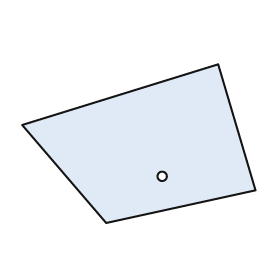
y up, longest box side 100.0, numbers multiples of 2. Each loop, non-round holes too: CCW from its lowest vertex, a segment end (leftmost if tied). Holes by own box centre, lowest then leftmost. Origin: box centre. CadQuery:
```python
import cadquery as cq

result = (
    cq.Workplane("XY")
    .moveTo(-14.0, -34.0)
    .lineTo(50.0, -20.0)
    .lineTo(34.0, 34.0)
    .lineTo(-50.0, 8.0)
    .close()
    .moveTo(10.0, -14.0)
    .circle(2.0)
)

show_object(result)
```